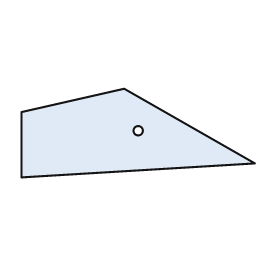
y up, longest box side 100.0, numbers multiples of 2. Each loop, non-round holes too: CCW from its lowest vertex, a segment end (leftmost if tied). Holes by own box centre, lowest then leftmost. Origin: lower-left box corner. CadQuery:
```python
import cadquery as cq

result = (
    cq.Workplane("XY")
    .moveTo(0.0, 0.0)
    .lineTo(100.0, 6.0)
    .lineTo(44.0, 38.0)
    .lineTo(0.0, 28.0)
    .close()
    .moveTo(50.0, 20.0)
    .circle(2.0)
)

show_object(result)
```